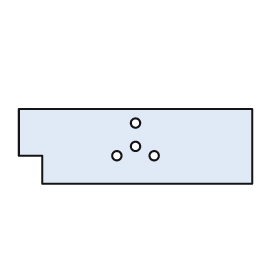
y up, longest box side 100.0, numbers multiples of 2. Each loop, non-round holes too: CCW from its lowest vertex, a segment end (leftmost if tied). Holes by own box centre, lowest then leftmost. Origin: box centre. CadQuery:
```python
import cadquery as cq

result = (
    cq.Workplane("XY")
    .moveTo(-40.0, -16.0)
    .lineTo(50.0, -16.0)
    .lineTo(50.0, 16.0)
    .lineTo(-50.0, 16.0)
    .lineTo(-50.0, -4.0)
    .lineTo(-40.0, -4.0)
    .close()
    .moveTo(-8.0, -4.0)
    .circle(2.0)
    .moveTo(8.0, -4.0)
    .circle(2.0)
    .moveTo(0.0, 0.0)
    .circle(2.0)
    .moveTo(0.0, 10.0)
    .circle(2.0)
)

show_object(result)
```